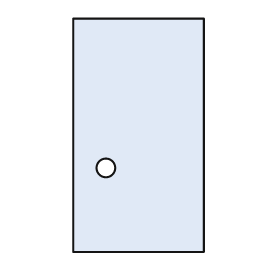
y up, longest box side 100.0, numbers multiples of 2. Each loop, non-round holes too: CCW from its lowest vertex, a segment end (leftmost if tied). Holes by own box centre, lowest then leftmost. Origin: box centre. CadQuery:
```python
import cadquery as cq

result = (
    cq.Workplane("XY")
    .moveTo(-28.0, -50.0)
    .lineTo(28.0, -50.0)
    .lineTo(28.0, 50.0)
    .lineTo(-28.0, 50.0)
    .close()
    .moveTo(-14.0, -14.0)
    .circle(4.0)
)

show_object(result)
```